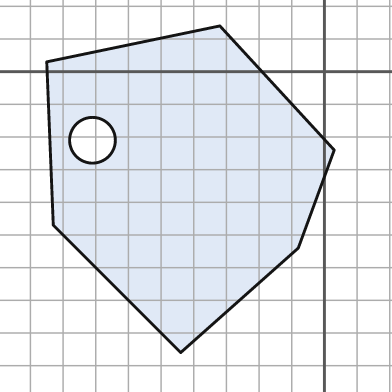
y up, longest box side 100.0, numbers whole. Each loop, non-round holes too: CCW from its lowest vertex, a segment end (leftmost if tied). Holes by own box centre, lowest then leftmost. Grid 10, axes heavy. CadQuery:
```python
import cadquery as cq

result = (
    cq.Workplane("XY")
    .moveTo(-44.0, -86.0)
    .lineTo(-8.0, -54.0)
    .lineTo(3.0, -24.0)
    .lineTo(-32.0, 14.0)
    .lineTo(-85.0, 3.0)
    .lineTo(-83.0, -47.0)
    .close()
    .moveTo(-71.0, -21.0)
    .circle(7.0)
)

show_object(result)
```